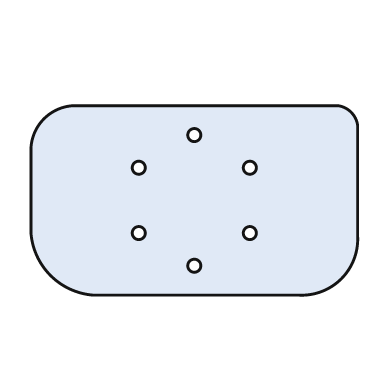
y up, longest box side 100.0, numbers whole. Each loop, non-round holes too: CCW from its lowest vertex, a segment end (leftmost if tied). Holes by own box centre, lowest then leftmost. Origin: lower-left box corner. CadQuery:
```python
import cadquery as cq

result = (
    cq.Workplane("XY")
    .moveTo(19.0, 0.0)
    .lineTo(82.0, 0.0)
    .threePointArc((95.0, 5.0), (100.0, 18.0))
    .lineTo(100.0, 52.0)
    .threePointArc((98.0, 56.0), (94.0, 58.0))
    .lineTo(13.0, 58.0)
    .threePointArc((4.0, 54.0), (0.0, 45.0))
    .lineTo(0.0, 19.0)
    .threePointArc((6.0, 6.0), (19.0, 0.0))
    .close()
    .moveTo(50.0, 9.0)
    .circle(2.0)
    .moveTo(33.0, 19.0)
    .circle(2.0)
    .moveTo(67.0, 19.0)
    .circle(2.0)
    .moveTo(33.0, 39.0)
    .circle(2.0)
    .moveTo(67.0, 39.0)
    .circle(2.0)
    .moveTo(50.0, 49.0)
    .circle(2.0)
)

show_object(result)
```